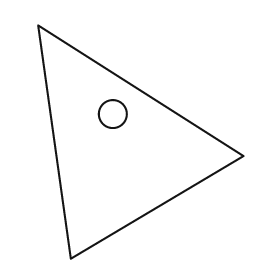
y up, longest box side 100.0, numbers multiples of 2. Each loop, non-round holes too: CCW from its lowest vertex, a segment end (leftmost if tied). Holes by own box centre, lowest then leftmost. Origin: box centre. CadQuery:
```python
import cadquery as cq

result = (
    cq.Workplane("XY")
    .moveTo(-30.0, -50.0)
    .lineTo(44.0, -6.0)
    .lineTo(-44.0, 50.0)
    .close()
    .moveTo(-12.0, 12.0)
    .circle(6.0)
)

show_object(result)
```